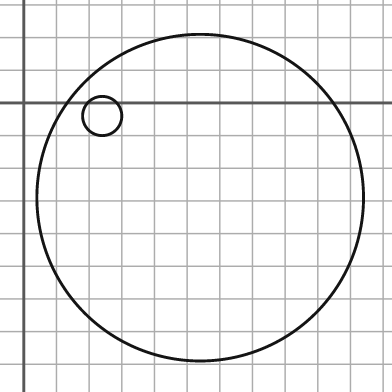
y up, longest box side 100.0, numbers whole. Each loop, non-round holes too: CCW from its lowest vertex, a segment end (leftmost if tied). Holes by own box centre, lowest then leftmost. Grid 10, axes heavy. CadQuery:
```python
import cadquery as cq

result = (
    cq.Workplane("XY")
    .moveTo(54.0, -29.0)
    .circle(50.0)
    .moveTo(24.0, -4.0)
    .circle(6.0)
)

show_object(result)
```